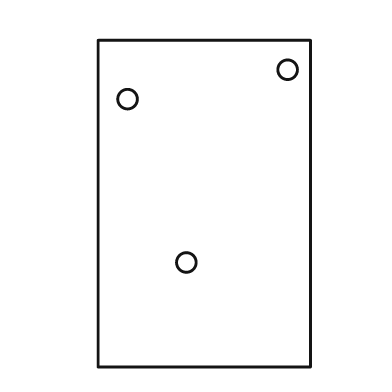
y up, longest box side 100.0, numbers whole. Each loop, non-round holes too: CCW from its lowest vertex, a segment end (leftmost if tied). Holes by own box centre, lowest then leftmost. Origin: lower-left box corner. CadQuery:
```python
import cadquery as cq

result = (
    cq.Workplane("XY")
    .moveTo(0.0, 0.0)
    .lineTo(65.0, 0.0)
    .lineTo(65.0, 100.0)
    .lineTo(0.0, 100.0)
    .close()
    .moveTo(27.0, 32.0)
    .circle(3.0)
    .moveTo(9.0, 82.0)
    .circle(3.0)
    .moveTo(58.0, 91.0)
    .circle(3.0)
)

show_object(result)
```